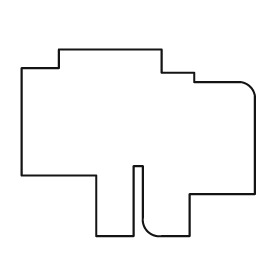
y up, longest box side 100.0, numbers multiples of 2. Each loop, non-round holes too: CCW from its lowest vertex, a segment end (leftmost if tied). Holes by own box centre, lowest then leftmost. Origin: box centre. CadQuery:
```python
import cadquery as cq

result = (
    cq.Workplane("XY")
    .moveTo(-18.0, -40.0)
    .lineTo(-2.0, -40.0)
    .lineTo(-2.0, -10.0)
    .lineTo(2.0, -10.0)
    .lineTo(2.0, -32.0)
    .threePointArc((4.0, -38.0), (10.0, -40.0))
    .lineTo(22.0, -40.0)
    .lineTo(22.0, -22.0)
    .lineTo(50.0, -22.0)
    .lineTo(50.0, 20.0)
    .threePointArc((48.0, 24.0), (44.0, 26.0))
    .lineTo(24.0, 26.0)
    .lineTo(24.0, 30.0)
    .lineTo(10.0, 30.0)
    .lineTo(10.0, 40.0)
    .lineTo(-34.0, 40.0)
    .lineTo(-34.0, 32.0)
    .lineTo(-50.0, 32.0)
    .lineTo(-50.0, -14.0)
    .lineTo(-18.0, -14.0)
    .close()
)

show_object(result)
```